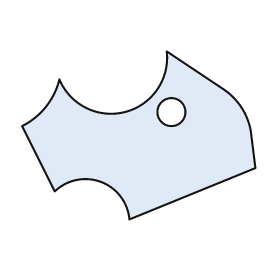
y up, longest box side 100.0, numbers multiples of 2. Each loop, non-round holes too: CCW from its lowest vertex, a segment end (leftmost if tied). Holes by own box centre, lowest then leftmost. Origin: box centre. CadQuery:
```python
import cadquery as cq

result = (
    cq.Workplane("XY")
    .moveTo(-4.0, -36.0)
    .lineTo(50.0, -14.0)
    .lineTo(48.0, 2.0)
    .threePointArc((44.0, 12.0), (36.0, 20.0))
    .lineTo(12.0, 36.0)
    .threePointArc((-6.0, 10.0), (-34.0, 24.0))
    .threePointArc((-40.0, 12.0), (-50.0, 4.0))
    .lineTo(-36.0, -24.0)
    .threePointArc((-16.0, -20.0), (-4.0, -36.0))
    .close()
    .moveTo(14.0, 10.0)
    .circle(6.0)
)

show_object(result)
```